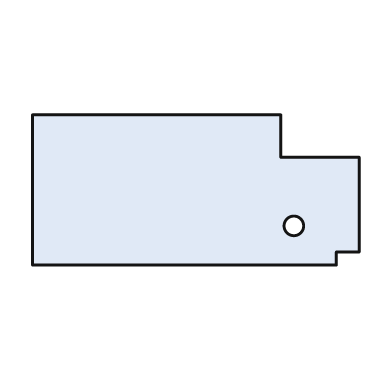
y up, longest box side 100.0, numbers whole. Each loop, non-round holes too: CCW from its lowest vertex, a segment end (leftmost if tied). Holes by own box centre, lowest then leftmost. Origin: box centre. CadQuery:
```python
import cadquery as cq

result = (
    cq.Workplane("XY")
    .moveTo(-50.0, -23.0)
    .lineTo(43.0, -23.0)
    .lineTo(43.0, -19.0)
    .lineTo(50.0, -19.0)
    .lineTo(50.0, 10.0)
    .lineTo(26.0, 10.0)
    .lineTo(26.0, 23.0)
    .lineTo(-50.0, 23.0)
    .close()
    .moveTo(30.0, -11.0)
    .circle(3.0)
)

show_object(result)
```